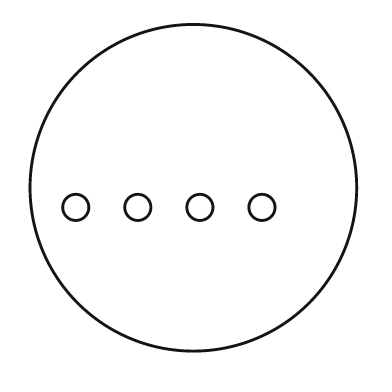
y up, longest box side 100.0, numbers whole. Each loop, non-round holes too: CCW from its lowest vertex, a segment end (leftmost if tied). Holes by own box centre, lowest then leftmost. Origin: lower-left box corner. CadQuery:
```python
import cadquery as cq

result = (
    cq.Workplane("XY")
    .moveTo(50.0, 50.0)
    .circle(50.0)
    .moveTo(14.0, 44.0)
    .circle(4.0)
    .moveTo(33.0, 44.0)
    .circle(4.0)
    .moveTo(52.0, 44.0)
    .circle(4.0)
    .moveTo(71.0, 44.0)
    .circle(4.0)
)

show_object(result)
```